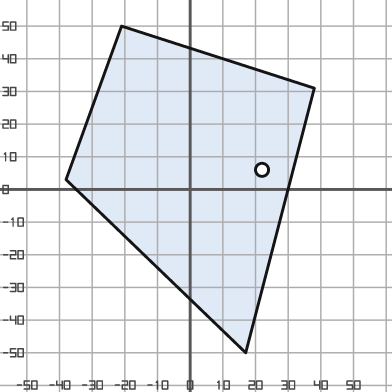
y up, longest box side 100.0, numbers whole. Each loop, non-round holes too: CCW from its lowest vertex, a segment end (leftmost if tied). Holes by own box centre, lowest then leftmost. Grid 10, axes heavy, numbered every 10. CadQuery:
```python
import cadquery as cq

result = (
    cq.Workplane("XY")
    .moveTo(17.0, -50.0)
    .lineTo(38.0, 31.0)
    .lineTo(-21.0, 50.0)
    .lineTo(-38.0, 3.0)
    .close()
    .moveTo(22.0, 6.0)
    .circle(2.0)
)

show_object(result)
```